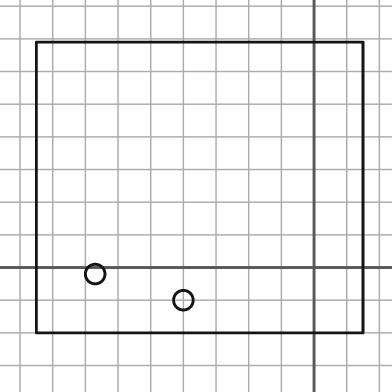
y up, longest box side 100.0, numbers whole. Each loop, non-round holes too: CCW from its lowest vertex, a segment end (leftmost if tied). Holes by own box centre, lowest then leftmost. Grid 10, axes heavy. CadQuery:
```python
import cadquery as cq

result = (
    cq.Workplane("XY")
    .moveTo(-85.0, -20.0)
    .lineTo(15.0, -20.0)
    .lineTo(15.0, 69.0)
    .lineTo(-85.0, 69.0)
    .close()
    .moveTo(-40.0, -10.0)
    .circle(3.0)
    .moveTo(-67.0, -2.0)
    .circle(3.0)
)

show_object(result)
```